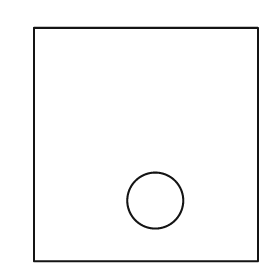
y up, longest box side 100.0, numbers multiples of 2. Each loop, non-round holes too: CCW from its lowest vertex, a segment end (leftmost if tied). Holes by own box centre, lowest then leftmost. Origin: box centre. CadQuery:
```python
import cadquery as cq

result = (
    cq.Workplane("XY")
    .moveTo(-48.0, -50.0)
    .lineTo(48.0, -50.0)
    .lineTo(48.0, 50.0)
    .lineTo(-48.0, 50.0)
    .close()
    .moveTo(4.0, -24.0)
    .circle(12.0)
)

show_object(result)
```